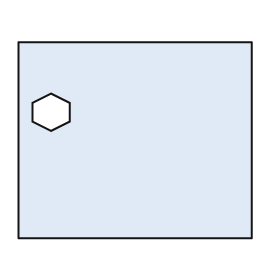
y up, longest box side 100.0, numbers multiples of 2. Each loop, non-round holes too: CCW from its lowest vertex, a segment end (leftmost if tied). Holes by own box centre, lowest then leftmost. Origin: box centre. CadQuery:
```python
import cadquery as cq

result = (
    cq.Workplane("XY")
    .moveTo(-50.0, -42.0)
    .lineTo(50.0, -42.0)
    .lineTo(50.0, 42.0)
    .lineTo(-50.0, 42.0)
    .close()
    .moveTo(-36.0, 4.0)
    .lineTo(-28.0, 8.0)
    .lineTo(-28.0, 16.0)
    .lineTo(-36.0, 20.0)
    .lineTo(-44.0, 16.0)
    .lineTo(-44.0, 8.0)
    .close()
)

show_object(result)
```